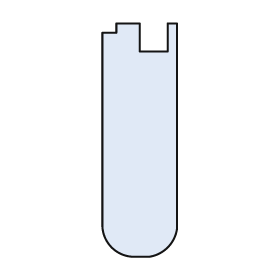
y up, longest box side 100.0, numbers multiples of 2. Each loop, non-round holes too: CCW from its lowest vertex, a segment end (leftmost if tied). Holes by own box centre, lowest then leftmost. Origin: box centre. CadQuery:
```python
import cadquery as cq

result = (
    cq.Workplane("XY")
    .moveTo(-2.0, -50.0)
    .lineTo(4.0, -50.0)
    .threePointArc((12.0, -46.0), (16.0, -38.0))
    .lineTo(16.0, 50.0)
    .lineTo(12.0, 50.0)
    .lineTo(12.0, 38.0)
    .lineTo(0.0, 38.0)
    .lineTo(0.0, 50.0)
    .lineTo(-10.0, 50.0)
    .lineTo(-10.0, 46.0)
    .lineTo(-16.0, 46.0)
    .lineTo(-16.0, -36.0)
    .threePointArc((-12.0, -46.0), (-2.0, -50.0))
    .close()
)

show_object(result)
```